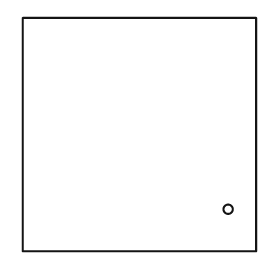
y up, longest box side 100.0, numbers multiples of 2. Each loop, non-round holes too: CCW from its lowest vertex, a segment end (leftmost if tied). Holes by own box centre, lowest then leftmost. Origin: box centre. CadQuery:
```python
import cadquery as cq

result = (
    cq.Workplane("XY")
    .moveTo(-50.0, -50.0)
    .lineTo(50.0, -50.0)
    .lineTo(50.0, 50.0)
    .lineTo(-50.0, 50.0)
    .close()
    .moveTo(38.0, -32.0)
    .circle(2.0)
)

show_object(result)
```